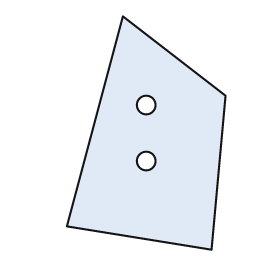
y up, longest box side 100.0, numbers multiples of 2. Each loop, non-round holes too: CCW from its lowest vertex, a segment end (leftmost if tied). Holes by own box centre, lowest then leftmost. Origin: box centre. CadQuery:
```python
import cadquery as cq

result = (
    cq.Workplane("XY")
    .moveTo(28.0, -50.0)
    .lineTo(34.0, 16.0)
    .lineTo(-10.0, 50.0)
    .lineTo(-34.0, -40.0)
    .close()
    .moveTo(0.0, -12.0)
    .circle(4.0)
    .moveTo(0.0, 12.0)
    .circle(4.0)
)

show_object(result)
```